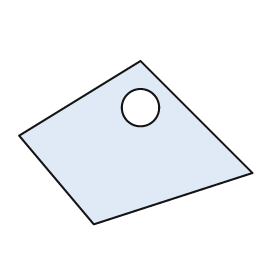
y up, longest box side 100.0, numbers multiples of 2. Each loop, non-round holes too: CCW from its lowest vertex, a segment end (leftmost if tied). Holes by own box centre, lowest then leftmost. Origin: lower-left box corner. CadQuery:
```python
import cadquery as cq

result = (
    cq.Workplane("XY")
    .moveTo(32.0, 0.0)
    .lineTo(100.0, 22.0)
    .lineTo(52.0, 70.0)
    .lineTo(0.0, 38.0)
    .close()
    .moveTo(52.0, 50.0)
    .circle(8.0)
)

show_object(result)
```